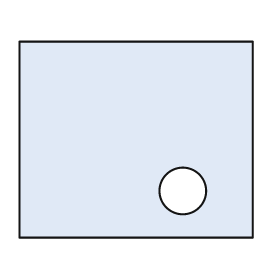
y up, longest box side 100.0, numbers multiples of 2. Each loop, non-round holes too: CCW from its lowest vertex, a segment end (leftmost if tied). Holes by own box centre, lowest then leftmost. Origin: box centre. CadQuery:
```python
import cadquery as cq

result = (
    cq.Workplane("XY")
    .moveTo(-50.0, -42.0)
    .lineTo(50.0, -42.0)
    .lineTo(50.0, 42.0)
    .lineTo(-50.0, 42.0)
    .close()
    .moveTo(20.0, -22.0)
    .circle(10.0)
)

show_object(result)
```